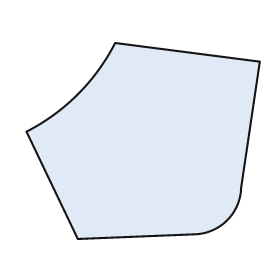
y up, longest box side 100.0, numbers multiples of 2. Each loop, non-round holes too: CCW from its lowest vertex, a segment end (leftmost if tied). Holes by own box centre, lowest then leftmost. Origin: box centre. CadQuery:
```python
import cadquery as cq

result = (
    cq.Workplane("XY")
    .moveTo(-28.0, -42.0)
    .lineTo(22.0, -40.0)
    .threePointArc((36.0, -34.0), (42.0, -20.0))
    .lineTo(50.0, 34.0)
    .lineTo(-12.0, 42.0)
    .threePointArc((-28.0, 20.0), (-50.0, 4.0))
    .close()
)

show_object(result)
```